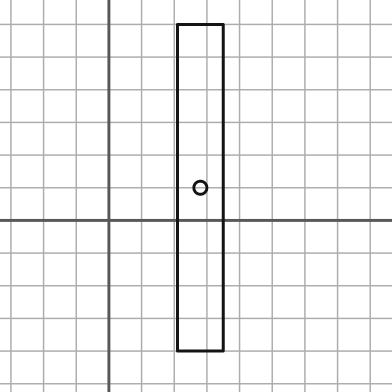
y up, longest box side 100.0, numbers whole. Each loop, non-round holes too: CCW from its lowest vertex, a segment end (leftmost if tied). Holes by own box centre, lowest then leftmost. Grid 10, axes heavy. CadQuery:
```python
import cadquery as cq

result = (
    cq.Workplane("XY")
    .moveTo(21.0, -40.0)
    .lineTo(35.0, -40.0)
    .lineTo(35.0, 60.0)
    .lineTo(21.0, 60.0)
    .close()
    .moveTo(28.0, 10.0)
    .circle(2.0)
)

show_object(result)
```